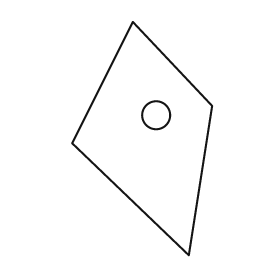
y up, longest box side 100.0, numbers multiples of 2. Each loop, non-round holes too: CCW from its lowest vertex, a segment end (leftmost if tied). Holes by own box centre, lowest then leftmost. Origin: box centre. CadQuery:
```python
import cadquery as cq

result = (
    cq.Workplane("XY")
    .moveTo(20.0, -50.0)
    .lineTo(30.0, 14.0)
    .lineTo(-4.0, 50.0)
    .lineTo(-30.0, -2.0)
    .close()
    .moveTo(6.0, 10.0)
    .circle(6.0)
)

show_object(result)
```